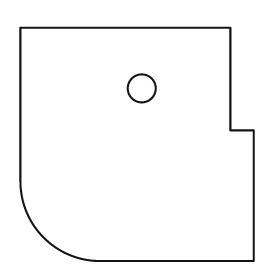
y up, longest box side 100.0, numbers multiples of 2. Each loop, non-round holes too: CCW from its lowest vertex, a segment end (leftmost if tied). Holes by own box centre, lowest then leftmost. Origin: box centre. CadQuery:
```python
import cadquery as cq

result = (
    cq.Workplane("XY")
    .moveTo(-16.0, -50.0)
    .lineTo(50.0, -50.0)
    .lineTo(50.0, 6.0)
    .lineTo(40.0, 6.0)
    .lineTo(40.0, 50.0)
    .lineTo(-50.0, 50.0)
    .lineTo(-50.0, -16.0)
    .threePointArc((-40.0, -40.0), (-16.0, -50.0))
    .close()
    .moveTo(2.0, 24.0)
    .circle(6.0)
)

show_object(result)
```